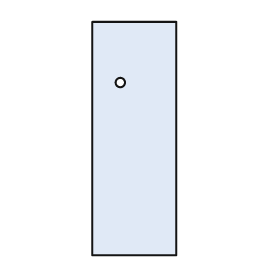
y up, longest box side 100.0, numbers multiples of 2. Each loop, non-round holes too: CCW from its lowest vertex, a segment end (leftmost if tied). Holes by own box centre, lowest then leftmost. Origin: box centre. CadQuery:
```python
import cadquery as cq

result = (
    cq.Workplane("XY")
    .moveTo(-18.0, -50.0)
    .lineTo(18.0, -50.0)
    .lineTo(18.0, 50.0)
    .lineTo(-18.0, 50.0)
    .close()
    .moveTo(-6.0, 24.0)
    .circle(2.0)
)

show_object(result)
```